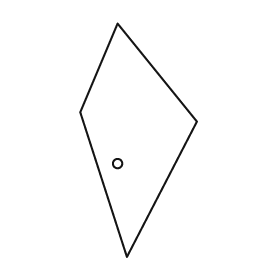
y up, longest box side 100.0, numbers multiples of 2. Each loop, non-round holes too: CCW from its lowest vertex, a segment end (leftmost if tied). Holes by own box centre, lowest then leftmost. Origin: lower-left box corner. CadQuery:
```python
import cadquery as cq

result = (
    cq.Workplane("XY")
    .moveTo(20.0, 0.0)
    .lineTo(50.0, 58.0)
    .lineTo(16.0, 100.0)
    .lineTo(0.0, 62.0)
    .close()
    .moveTo(16.0, 40.0)
    .circle(2.0)
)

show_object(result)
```